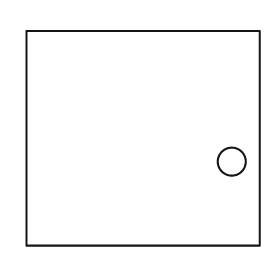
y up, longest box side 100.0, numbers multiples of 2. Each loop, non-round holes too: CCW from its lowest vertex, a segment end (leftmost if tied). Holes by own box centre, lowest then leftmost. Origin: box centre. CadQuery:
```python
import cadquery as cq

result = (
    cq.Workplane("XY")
    .moveTo(-50.0, -46.0)
    .lineTo(50.0, -46.0)
    .lineTo(50.0, 46.0)
    .lineTo(-50.0, 46.0)
    .close()
    .moveTo(38.0, -10.0)
    .circle(6.0)
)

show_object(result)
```